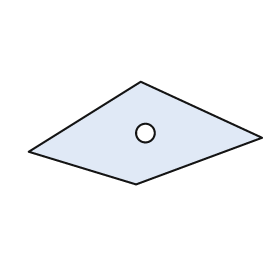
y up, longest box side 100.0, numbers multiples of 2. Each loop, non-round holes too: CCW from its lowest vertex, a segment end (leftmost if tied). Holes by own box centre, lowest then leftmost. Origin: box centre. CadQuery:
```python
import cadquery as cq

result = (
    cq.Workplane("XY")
    .moveTo(-4.0, -22.0)
    .lineTo(50.0, -2.0)
    .lineTo(-2.0, 22.0)
    .lineTo(-50.0, -8.0)
    .close()
    .moveTo(0.0, 0.0)
    .circle(4.0)
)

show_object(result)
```